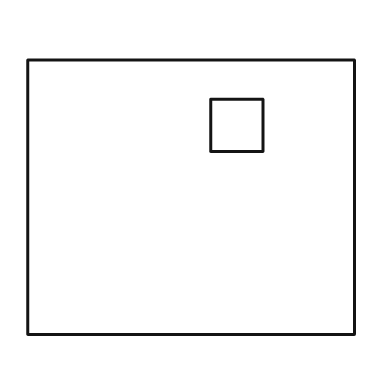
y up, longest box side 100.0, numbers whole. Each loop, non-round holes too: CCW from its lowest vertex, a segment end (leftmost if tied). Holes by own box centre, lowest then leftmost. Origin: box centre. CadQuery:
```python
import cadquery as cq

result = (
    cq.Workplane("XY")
    .moveTo(-50.0, -42.0)
    .lineTo(50.0, -42.0)
    .lineTo(50.0, 42.0)
    .lineTo(-50.0, 42.0)
    .close()
    .moveTo(6.0, 14.0)
    .lineTo(22.0, 14.0)
    .lineTo(22.0, 30.0)
    .lineTo(6.0, 30.0)
    .close()
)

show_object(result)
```